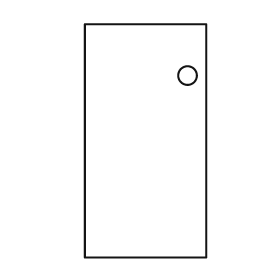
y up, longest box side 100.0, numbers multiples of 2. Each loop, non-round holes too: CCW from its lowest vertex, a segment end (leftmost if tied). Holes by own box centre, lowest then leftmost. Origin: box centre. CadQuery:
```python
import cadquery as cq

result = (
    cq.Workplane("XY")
    .moveTo(-26.0, -50.0)
    .lineTo(26.0, -50.0)
    .lineTo(26.0, 50.0)
    .lineTo(-26.0, 50.0)
    .close()
    .moveTo(18.0, 28.0)
    .circle(4.0)
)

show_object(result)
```